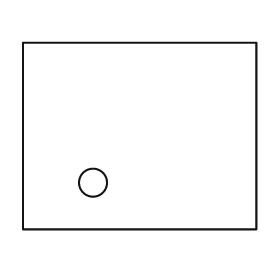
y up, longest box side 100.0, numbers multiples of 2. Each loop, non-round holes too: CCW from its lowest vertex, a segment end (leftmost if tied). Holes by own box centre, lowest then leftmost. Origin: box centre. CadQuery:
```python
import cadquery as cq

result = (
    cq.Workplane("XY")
    .moveTo(-50.0, -40.0)
    .lineTo(50.0, -40.0)
    .lineTo(50.0, 40.0)
    .lineTo(-50.0, 40.0)
    .close()
    .moveTo(-20.0, -20.0)
    .circle(6.0)
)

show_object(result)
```